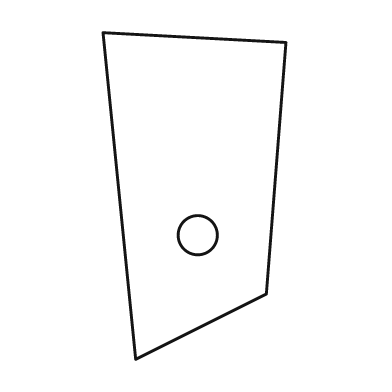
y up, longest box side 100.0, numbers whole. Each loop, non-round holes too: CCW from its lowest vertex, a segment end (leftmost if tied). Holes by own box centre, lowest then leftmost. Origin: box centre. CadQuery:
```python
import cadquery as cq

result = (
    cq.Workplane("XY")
    .moveTo(-18.0, -50.0)
    .lineTo(22.0, -30.0)
    .lineTo(28.0, 47.0)
    .lineTo(-28.0, 50.0)
    .close()
    .moveTo(1.0, -12.0)
    .circle(6.0)
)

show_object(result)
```